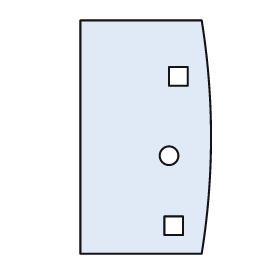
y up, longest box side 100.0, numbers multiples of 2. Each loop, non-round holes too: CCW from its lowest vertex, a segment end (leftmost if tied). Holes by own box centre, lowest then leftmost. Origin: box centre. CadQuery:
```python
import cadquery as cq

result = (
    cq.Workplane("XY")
    .moveTo(-28.0, -50.0)
    .lineTo(24.0, -50.0)
    .threePointArc((28.0, 0.0), (24.0, 50.0))
    .lineTo(-28.0, 50.0)
    .close()
    .moveTo(8.0, -42.0)
    .lineTo(16.0, -42.0)
    .lineTo(16.0, -34.0)
    .lineTo(8.0, -34.0)
    .close()
    .moveTo(10.0, -8.0)
    .circle(4.0)
    .moveTo(10.0, 22.0)
    .lineTo(18.0, 22.0)
    .lineTo(18.0, 30.0)
    .lineTo(10.0, 30.0)
    .close()
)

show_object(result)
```